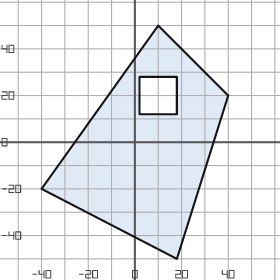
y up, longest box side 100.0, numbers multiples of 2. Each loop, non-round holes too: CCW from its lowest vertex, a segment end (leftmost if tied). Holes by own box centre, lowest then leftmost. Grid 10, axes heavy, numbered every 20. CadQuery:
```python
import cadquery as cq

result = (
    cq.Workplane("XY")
    .moveTo(18.0, -50.0)
    .lineTo(40.0, 20.0)
    .lineTo(10.0, 50.0)
    .lineTo(-40.0, -20.0)
    .close()
    .moveTo(2.0, 12.0)
    .lineTo(18.0, 12.0)
    .lineTo(18.0, 28.0)
    .lineTo(2.0, 28.0)
    .close()
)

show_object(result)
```